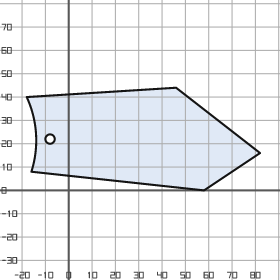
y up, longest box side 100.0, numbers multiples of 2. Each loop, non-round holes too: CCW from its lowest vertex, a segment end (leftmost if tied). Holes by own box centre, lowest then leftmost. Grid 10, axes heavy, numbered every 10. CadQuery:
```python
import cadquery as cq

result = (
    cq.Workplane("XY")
    .moveTo(58.0, 0.0)
    .lineTo(82.0, 16.0)
    .lineTo(46.0, 44.0)
    .lineTo(-18.0, 40.0)
    .threePointArc((-14.0, 24.0), (-16.0, 8.0))
    .close()
    .moveTo(-8.0, 22.0)
    .circle(2.0)
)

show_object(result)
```